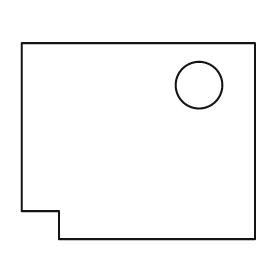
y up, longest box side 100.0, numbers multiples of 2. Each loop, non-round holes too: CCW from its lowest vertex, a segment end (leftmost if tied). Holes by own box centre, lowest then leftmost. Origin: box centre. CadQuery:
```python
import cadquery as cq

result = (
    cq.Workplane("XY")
    .moveTo(-34.0, -42.0)
    .lineTo(50.0, -42.0)
    .lineTo(50.0, 42.0)
    .lineTo(-50.0, 42.0)
    .lineTo(-50.0, -30.0)
    .lineTo(-34.0, -30.0)
    .close()
    .moveTo(26.0, 24.0)
    .circle(10.0)
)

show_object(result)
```